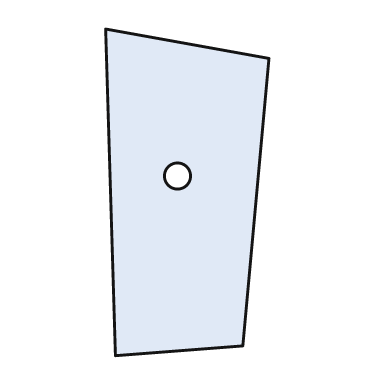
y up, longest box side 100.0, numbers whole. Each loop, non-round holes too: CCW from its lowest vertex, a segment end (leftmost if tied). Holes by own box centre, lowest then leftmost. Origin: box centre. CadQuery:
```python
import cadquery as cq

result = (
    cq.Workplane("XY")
    .moveTo(-22.0, -50.0)
    .lineTo(17.0, -47.0)
    .lineTo(25.0, 41.0)
    .lineTo(-25.0, 50.0)
    .close()
    .moveTo(-3.0, 5.0)
    .circle(4.0)
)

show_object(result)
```